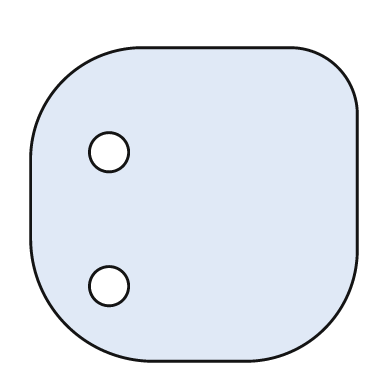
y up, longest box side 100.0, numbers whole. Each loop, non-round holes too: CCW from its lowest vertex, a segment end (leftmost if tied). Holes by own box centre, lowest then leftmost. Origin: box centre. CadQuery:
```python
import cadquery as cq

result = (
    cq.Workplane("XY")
    .moveTo(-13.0, -48.0)
    .lineTo(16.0, -48.0)
    .threePointArc((40.0, -38.0), (50.0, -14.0))
    .lineTo(50.0, 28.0)
    .threePointArc((44.0, 42.0), (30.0, 48.0))
    .lineTo(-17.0, 48.0)
    .threePointArc((-40.0, 38.0), (-50.0, 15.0))
    .lineTo(-50.0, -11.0)
    .threePointArc((-39.0, -37.0), (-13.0, -48.0))
    .close()
    .moveTo(-26.0, -25.0)
    .circle(6.0)
    .moveTo(-26.0, 16.0)
    .circle(6.0)
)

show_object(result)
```